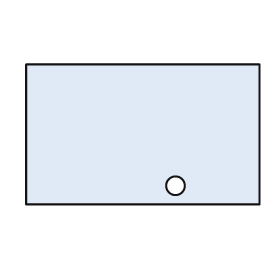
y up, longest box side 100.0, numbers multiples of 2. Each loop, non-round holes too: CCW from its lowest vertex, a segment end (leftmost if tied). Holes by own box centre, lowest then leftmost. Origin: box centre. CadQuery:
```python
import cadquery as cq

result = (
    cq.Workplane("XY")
    .moveTo(-50.0, -30.0)
    .lineTo(50.0, -30.0)
    .lineTo(50.0, 30.0)
    .lineTo(-50.0, 30.0)
    .close()
    .moveTo(14.0, -22.0)
    .circle(4.0)
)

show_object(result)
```